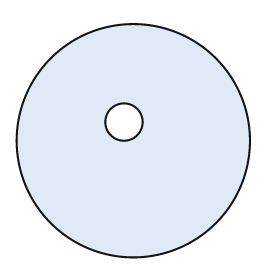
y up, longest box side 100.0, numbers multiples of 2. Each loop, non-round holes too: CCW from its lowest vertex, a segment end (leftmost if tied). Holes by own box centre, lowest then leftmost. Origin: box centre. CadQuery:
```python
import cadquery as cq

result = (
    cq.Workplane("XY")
    .moveTo(0.0, 0.0)
    .circle(50.0)
    .moveTo(-4.0, 8.0)
    .circle(8.0)
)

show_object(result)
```